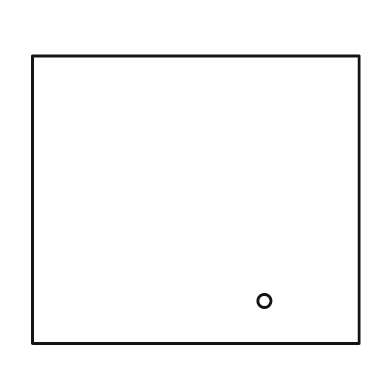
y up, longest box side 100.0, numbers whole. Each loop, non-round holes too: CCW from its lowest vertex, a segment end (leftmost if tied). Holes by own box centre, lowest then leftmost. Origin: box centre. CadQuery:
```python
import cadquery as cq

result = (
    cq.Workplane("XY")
    .moveTo(-50.0, -44.0)
    .lineTo(50.0, -44.0)
    .lineTo(50.0, 44.0)
    .lineTo(-50.0, 44.0)
    .close()
    .moveTo(21.0, -31.0)
    .circle(2.0)
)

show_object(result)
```